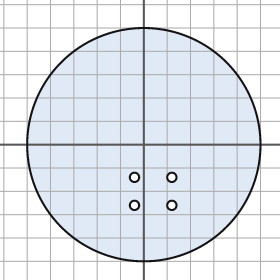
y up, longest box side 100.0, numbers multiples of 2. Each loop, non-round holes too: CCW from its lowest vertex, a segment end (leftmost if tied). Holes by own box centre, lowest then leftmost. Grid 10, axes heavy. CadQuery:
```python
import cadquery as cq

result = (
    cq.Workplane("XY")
    .moveTo(0.0, 0.0)
    .circle(50.0)
    .moveTo(-4.0, -26.0)
    .circle(2.0)
    .moveTo(12.0, -26.0)
    .circle(2.0)
    .moveTo(-4.0, -14.0)
    .circle(2.0)
    .moveTo(12.0, -14.0)
    .circle(2.0)
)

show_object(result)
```